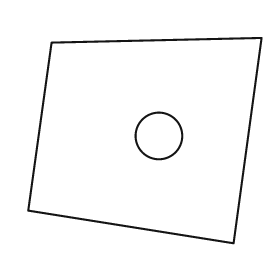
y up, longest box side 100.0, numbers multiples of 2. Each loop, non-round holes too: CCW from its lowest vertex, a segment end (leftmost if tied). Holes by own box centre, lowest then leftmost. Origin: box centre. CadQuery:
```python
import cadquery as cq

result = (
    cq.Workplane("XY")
    .moveTo(38.0, -44.0)
    .lineTo(50.0, 44.0)
    .lineTo(-40.0, 42.0)
    .lineTo(-50.0, -30.0)
    .close()
    .moveTo(6.0, 2.0)
    .circle(10.0)
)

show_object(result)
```